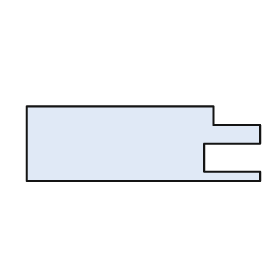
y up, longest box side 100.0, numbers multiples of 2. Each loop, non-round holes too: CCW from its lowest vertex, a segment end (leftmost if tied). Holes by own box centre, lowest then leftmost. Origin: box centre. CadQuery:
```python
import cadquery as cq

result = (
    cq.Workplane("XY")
    .moveTo(-50.0, -16.0)
    .lineTo(50.0, -16.0)
    .lineTo(50.0, -12.0)
    .lineTo(26.0, -12.0)
    .lineTo(26.0, 0.0)
    .lineTo(50.0, 0.0)
    .lineTo(50.0, 8.0)
    .lineTo(30.0, 8.0)
    .lineTo(30.0, 16.0)
    .lineTo(-50.0, 16.0)
    .close()
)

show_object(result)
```